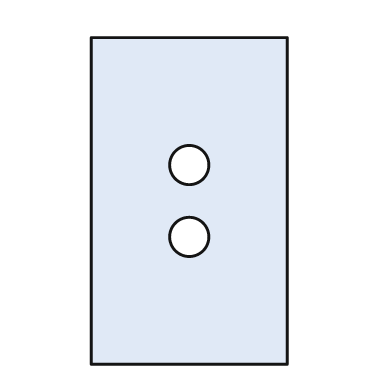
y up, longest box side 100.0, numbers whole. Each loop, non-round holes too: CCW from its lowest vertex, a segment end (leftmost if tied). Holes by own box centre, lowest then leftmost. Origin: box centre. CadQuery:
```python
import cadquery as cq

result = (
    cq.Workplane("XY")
    .moveTo(-30.0, -50.0)
    .lineTo(30.0, -50.0)
    .lineTo(30.0, 50.0)
    .lineTo(-30.0, 50.0)
    .close()
    .moveTo(0.0, -11.0)
    .circle(6.0)
    .moveTo(0.0, 11.0)
    .circle(6.0)
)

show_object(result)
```